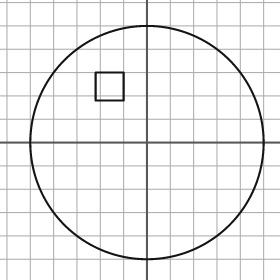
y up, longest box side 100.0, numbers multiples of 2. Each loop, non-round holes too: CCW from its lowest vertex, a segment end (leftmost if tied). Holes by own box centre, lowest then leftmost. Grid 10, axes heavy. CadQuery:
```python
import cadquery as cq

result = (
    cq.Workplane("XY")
    .moveTo(0.0, 0.0)
    .circle(50.0)
    .moveTo(-22.0, 18.0)
    .lineTo(-10.0, 18.0)
    .lineTo(-10.0, 30.0)
    .lineTo(-22.0, 30.0)
    .close()
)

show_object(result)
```